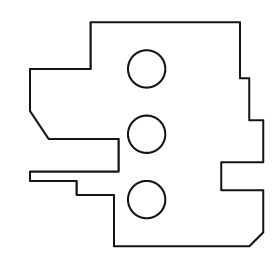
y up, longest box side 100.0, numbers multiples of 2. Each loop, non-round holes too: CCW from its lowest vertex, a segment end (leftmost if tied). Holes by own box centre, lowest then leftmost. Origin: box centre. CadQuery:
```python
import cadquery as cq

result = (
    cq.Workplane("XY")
    .moveTo(-14.0, -48.0)
    .lineTo(44.0, -48.0)
    .lineTo(50.0, -42.0)
    .lineTo(50.0, -24.0)
    .lineTo(32.0, -24.0)
    .lineTo(32.0, -12.0)
    .lineTo(50.0, -12.0)
    .lineTo(50.0, 6.0)
    .lineTo(44.0, 6.0)
    .lineTo(44.0, 24.0)
    .lineTo(40.0, 24.0)
    .lineTo(40.0, 48.0)
    .lineTo(-24.0, 48.0)
    .lineTo(-24.0, 28.0)
    .lineTo(-50.0, 28.0)
    .lineTo(-50.0, 10.0)
    .lineTo(-42.0, -2.0)
    .lineTo(-12.0, -2.0)
    .lineTo(-12.0, -16.0)
    .lineTo(-50.0, -16.0)
    .lineTo(-50.0, -20.0)
    .lineTo(-30.0, -20.0)
    .lineTo(-30.0, -26.0)
    .lineTo(-14.0, -26.0)
    .close()
    .moveTo(0.0, -28.0)
    .circle(8.0)
    .moveTo(0.0, 0.0)
    .circle(8.0)
    .moveTo(0.0, 28.0)
    .circle(8.0)
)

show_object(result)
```